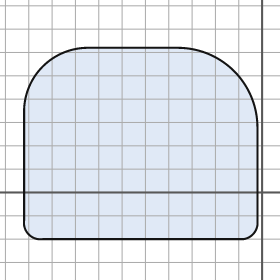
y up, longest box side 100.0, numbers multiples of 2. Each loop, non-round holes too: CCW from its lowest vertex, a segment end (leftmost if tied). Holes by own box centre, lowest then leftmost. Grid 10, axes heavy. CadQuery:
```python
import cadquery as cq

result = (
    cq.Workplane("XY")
    .moveTo(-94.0, -20.0)
    .lineTo(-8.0, -20.0)
    .threePointArc((-4.0, -18.0), (-2.0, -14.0))
    .lineTo(-2.0, 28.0)
    .threePointArc((-12.0, 52.0), (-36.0, 62.0))
    .lineTo(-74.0, 62.0)
    .threePointArc((-94.0, 54.0), (-102.0, 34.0))
    .lineTo(-102.0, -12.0)
    .threePointArc((-100.0, -18.0), (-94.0, -20.0))
    .close()
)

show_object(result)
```